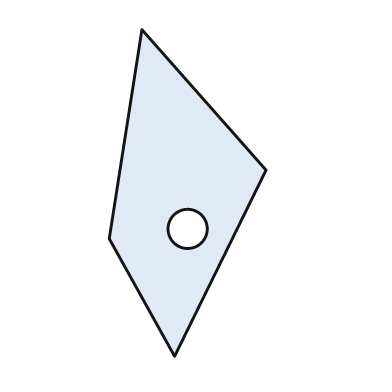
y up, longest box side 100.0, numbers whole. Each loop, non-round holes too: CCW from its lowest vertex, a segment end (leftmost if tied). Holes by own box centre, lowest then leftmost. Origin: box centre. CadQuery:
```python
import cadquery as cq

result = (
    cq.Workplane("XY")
    .moveTo(-4.0, -50.0)
    .lineTo(24.0, 7.0)
    .lineTo(-14.0, 50.0)
    .lineTo(-24.0, -14.0)
    .close()
    .moveTo(0.0, -11.0)
    .circle(6.0)
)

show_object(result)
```